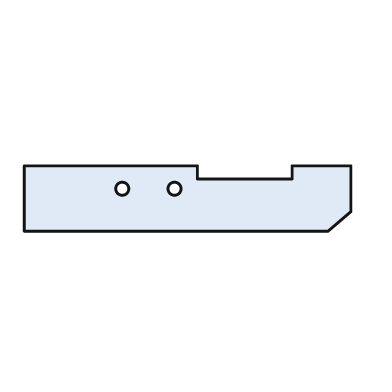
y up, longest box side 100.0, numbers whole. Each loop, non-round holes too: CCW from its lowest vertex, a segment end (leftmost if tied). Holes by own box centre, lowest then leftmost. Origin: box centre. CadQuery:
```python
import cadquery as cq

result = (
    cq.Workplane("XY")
    .moveTo(-50.0, -10.0)
    .lineTo(43.0, -10.0)
    .lineTo(50.0, -4.0)
    .lineTo(50.0, 10.0)
    .lineTo(32.0, 10.0)
    .lineTo(32.0, 6.0)
    .lineTo(3.0, 6.0)
    .lineTo(3.0, 10.0)
    .lineTo(-50.0, 10.0)
    .close()
    .moveTo(-20.0, 3.0)
    .circle(2.0)
    .moveTo(-4.0, 3.0)
    .circle(2.0)
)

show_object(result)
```